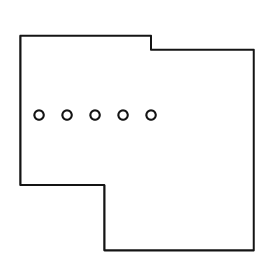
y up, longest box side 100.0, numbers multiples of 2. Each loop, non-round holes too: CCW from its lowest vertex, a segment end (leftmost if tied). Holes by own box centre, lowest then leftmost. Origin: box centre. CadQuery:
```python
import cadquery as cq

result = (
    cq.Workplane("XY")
    .moveTo(-14.0, -46.0)
    .lineTo(50.0, -46.0)
    .lineTo(50.0, 40.0)
    .lineTo(6.0, 40.0)
    .lineTo(6.0, 46.0)
    .lineTo(-50.0, 46.0)
    .lineTo(-50.0, -18.0)
    .lineTo(-14.0, -18.0)
    .close()
    .moveTo(-42.0, 12.0)
    .circle(2.0)
    .moveTo(-30.0, 12.0)
    .circle(2.0)
    .moveTo(-18.0, 12.0)
    .circle(2.0)
    .moveTo(-6.0, 12.0)
    .circle(2.0)
    .moveTo(6.0, 12.0)
    .circle(2.0)
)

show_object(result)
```